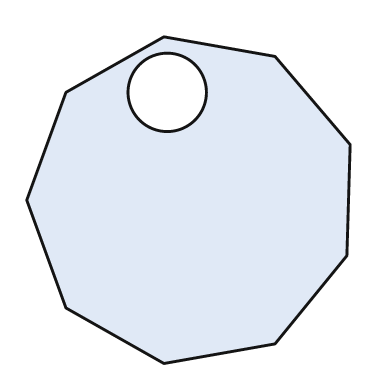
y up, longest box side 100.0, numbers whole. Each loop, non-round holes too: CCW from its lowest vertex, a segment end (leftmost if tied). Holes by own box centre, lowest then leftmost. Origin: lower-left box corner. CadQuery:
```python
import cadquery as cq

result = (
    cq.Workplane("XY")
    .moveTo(42.0, 0.0)
    .lineTo(76.0, 6.0)
    .lineTo(98.0, 33.0)
    .lineTo(99.0, 67.0)
    .lineTo(76.0, 94.0)
    .lineTo(42.0, 100.0)
    .lineTo(12.0, 83.0)
    .lineTo(0.0, 50.0)
    .lineTo(12.0, 17.0)
    .close()
    .moveTo(43.0, 83.0)
    .circle(12.0)
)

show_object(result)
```